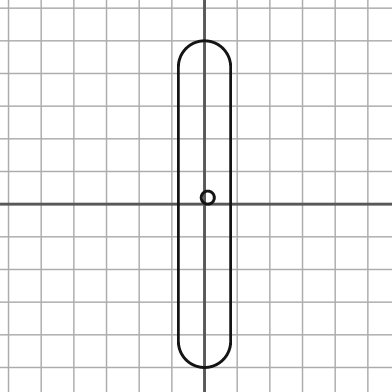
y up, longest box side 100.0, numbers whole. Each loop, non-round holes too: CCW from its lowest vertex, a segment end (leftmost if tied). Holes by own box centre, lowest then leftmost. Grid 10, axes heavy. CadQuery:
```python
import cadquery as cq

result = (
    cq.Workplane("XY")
    .moveTo(-8.0, -42.0)
    .threePointArc((0.0, -50.0), (8.0, -42.0))
    .lineTo(8.0, 42.0)
    .threePointArc((0.0, 50.0), (-8.0, 42.0))
    .close()
    .moveTo(1.0, 2.0)
    .circle(2.0)
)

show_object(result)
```